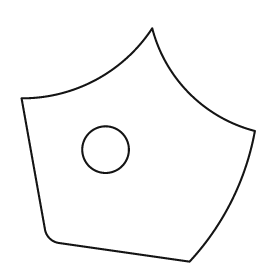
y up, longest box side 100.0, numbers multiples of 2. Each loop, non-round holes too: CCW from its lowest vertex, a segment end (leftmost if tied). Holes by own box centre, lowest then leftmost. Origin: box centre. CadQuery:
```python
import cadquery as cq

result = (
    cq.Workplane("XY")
    .moveTo(22.0, -50.0)
    .threePointArc((40.0, -24.0), (50.0, 6.0))
    .threePointArc((22.0, 22.0), (6.0, 50.0))
    .threePointArc((-18.0, 28.0), (-50.0, 20.0))
    .lineTo(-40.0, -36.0)
    .threePointArc((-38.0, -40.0), (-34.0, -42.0))
    .close()
    .moveTo(-14.0, -2.0)
    .circle(10.0)
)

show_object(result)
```